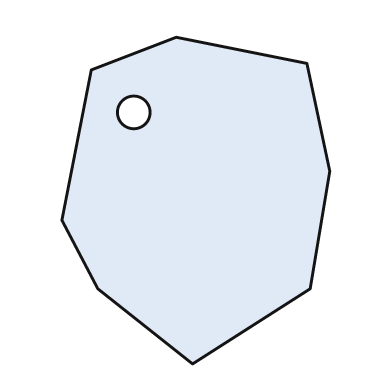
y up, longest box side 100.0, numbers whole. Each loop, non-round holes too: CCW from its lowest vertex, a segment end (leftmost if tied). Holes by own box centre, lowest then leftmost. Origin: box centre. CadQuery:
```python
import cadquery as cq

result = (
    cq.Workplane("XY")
    .moveTo(-1.0, -50.0)
    .lineTo(35.0, -27.0)
    .lineTo(41.0, 9.0)
    .lineTo(34.0, 42.0)
    .lineTo(-6.0, 50.0)
    .lineTo(-32.0, 40.0)
    .lineTo(-41.0, -6.0)
    .lineTo(-30.0, -27.0)
    .close()
    .moveTo(-19.0, 27.0)
    .circle(5.0)
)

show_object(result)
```